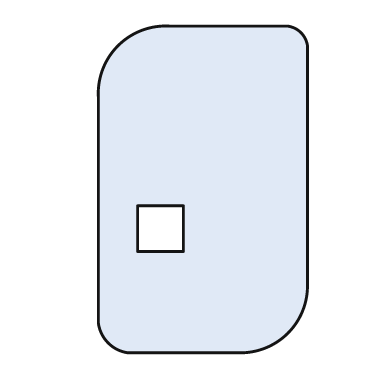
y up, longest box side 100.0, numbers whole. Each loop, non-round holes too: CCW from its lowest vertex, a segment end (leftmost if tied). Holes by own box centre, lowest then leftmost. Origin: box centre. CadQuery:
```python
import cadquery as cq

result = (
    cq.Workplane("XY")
    .moveTo(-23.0, -50.0)
    .lineTo(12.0, -50.0)
    .threePointArc((26.0, -44.0), (32.0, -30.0))
    .lineTo(32.0, 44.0)
    .threePointArc((30.0, 48.0), (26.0, 50.0))
    .lineTo(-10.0, 50.0)
    .threePointArc((-26.0, 44.0), (-32.0, 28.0))
    .lineTo(-32.0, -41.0)
    .threePointArc((-29.0, -47.0), (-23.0, -50.0))
    .close()
    .moveTo(-20.0, -19.0)
    .lineTo(-6.0, -19.0)
    .lineTo(-6.0, -5.0)
    .lineTo(-20.0, -5.0)
    .close()
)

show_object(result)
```